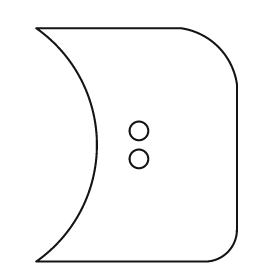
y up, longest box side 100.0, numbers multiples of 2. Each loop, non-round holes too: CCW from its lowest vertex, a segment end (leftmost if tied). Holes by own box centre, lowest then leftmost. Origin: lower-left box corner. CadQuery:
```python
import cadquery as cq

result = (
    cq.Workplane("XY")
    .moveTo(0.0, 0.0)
    .lineTo(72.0, 0.0)
    .threePointArc((82.0, 4.0), (86.0, 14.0))
    .lineTo(86.0, 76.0)
    .threePointArc((78.0, 92.0), (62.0, 100.0))
    .lineTo(0.0, 100.0)
    .threePointArc((26.0, 50.0), (0.0, 0.0))
    .close()
    .moveTo(44.0, 44.0)
    .circle(4.0)
    .moveTo(44.0, 56.0)
    .circle(4.0)
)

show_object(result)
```